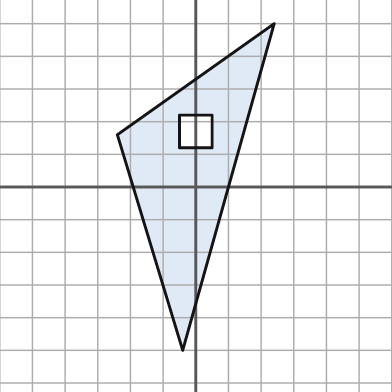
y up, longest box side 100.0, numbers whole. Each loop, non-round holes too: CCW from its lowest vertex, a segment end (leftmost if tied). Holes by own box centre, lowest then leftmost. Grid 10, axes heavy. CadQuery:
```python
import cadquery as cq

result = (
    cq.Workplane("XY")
    .moveTo(-4.0, -50.0)
    .lineTo(24.0, 50.0)
    .lineTo(-24.0, 16.0)
    .close()
    .moveTo(-5.0, 12.0)
    .lineTo(5.0, 12.0)
    .lineTo(5.0, 22.0)
    .lineTo(-5.0, 22.0)
    .close()
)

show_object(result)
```